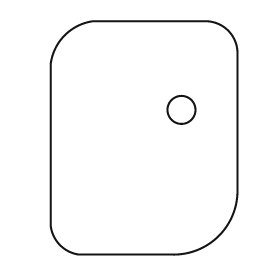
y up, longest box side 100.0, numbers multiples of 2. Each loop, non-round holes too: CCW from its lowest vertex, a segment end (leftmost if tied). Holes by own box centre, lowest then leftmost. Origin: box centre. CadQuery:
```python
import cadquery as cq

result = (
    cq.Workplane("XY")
    .moveTo(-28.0, -50.0)
    .lineTo(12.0, -50.0)
    .threePointArc((32.0, -42.0), (40.0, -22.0))
    .lineTo(40.0, 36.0)
    .threePointArc((36.0, 46.0), (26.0, 50.0))
    .lineTo(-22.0, 50.0)
    .threePointArc((-34.0, 44.0), (-40.0, 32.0))
    .lineTo(-40.0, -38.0)
    .threePointArc((-36.0, -46.0), (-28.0, -50.0))
    .close()
    .moveTo(16.0, 12.0)
    .circle(6.0)
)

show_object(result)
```